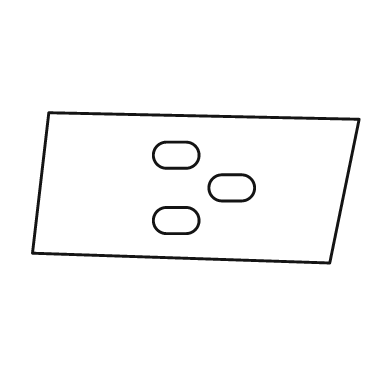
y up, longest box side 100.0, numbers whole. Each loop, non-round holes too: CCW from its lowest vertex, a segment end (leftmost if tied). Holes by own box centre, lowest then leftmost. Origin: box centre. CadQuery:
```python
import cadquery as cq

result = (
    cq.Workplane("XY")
    .moveTo(41.0, -23.0)
    .lineTo(50.0, 21.0)
    .lineTo(-45.0, 23.0)
    .lineTo(-50.0, -20.0)
    .close()
    .moveTo(-9.0, -14.0)
    .lineTo(-3.0, -14.0)
    .threePointArc((1.0, -10.0), (-3.0, -6.0))
    .lineTo(-9.0, -6.0)
    .threePointArc((-13.0, -10.0), (-9.0, -14.0))
    .close()
    .moveTo(8.0, -4.0)
    .lineTo(14.0, -4.0)
    .threePointArc((18.0, 0.0), (14.0, 4.0))
    .lineTo(8.0, 4.0)
    .threePointArc((4.0, 0.0), (8.0, -4.0))
    .close()
    .moveTo(-9.0, 6.0)
    .lineTo(-3.0, 6.0)
    .threePointArc((1.0, 10.0), (-3.0, 14.0))
    .lineTo(-9.0, 14.0)
    .threePointArc((-13.0, 10.0), (-9.0, 6.0))
    .close()
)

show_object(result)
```